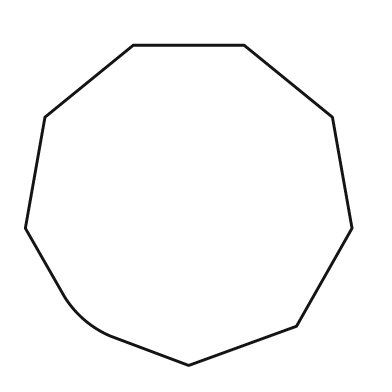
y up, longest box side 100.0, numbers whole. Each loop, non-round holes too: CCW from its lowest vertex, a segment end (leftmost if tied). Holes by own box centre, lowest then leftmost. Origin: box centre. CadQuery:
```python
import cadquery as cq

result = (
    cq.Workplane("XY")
    .moveTo(0.0, -49.0)
    .lineTo(33.0, -37.0)
    .lineTo(50.0, -7.0)
    .lineTo(44.0, 27.0)
    .lineTo(17.0, 49.0)
    .lineTo(-17.0, 49.0)
    .lineTo(-44.0, 27.0)
    .lineTo(-50.0, -7.0)
    .lineTo(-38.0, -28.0)
    .threePointArc((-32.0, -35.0), (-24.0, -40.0))
    .close()
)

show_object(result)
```